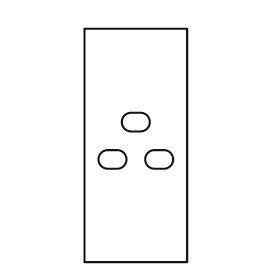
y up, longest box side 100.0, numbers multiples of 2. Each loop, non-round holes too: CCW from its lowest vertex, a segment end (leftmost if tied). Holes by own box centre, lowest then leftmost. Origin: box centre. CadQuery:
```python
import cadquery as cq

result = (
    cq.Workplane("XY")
    .moveTo(-22.0, -50.0)
    .lineTo(22.0, -50.0)
    .lineTo(22.0, 50.0)
    .lineTo(-22.0, 50.0)
    .close()
    .moveTo(-12.0, -10.0)
    .lineTo(-8.0, -10.0)
    .threePointArc((-4.0, -6.0), (-8.0, -2.0))
    .lineTo(-12.0, -2.0)
    .threePointArc((-16.0, -6.0), (-12.0, -10.0))
    .close()
    .moveTo(8.0, -10.0)
    .lineTo(12.0, -10.0)
    .threePointArc((16.0, -6.0), (12.0, -2.0))
    .lineTo(8.0, -2.0)
    .threePointArc((4.0, -6.0), (8.0, -10.0))
    .close()
    .moveTo(-2.0, 6.0)
    .lineTo(2.0, 6.0)
    .threePointArc((6.0, 10.0), (2.0, 14.0))
    .lineTo(-2.0, 14.0)
    .threePointArc((-6.0, 10.0), (-2.0, 6.0))
    .close()
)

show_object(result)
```